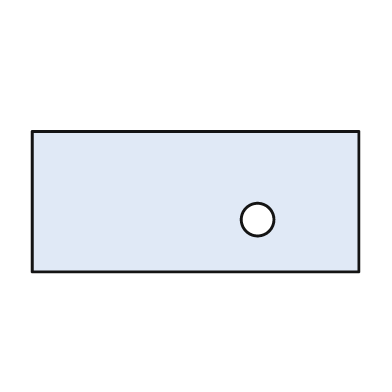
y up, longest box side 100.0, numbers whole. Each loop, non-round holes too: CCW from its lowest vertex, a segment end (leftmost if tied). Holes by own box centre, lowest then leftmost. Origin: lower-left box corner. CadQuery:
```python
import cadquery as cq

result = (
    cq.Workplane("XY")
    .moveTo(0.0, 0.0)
    .lineTo(100.0, 0.0)
    .lineTo(100.0, 43.0)
    .lineTo(0.0, 43.0)
    .close()
    .moveTo(69.0, 16.0)
    .circle(5.0)
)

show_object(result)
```